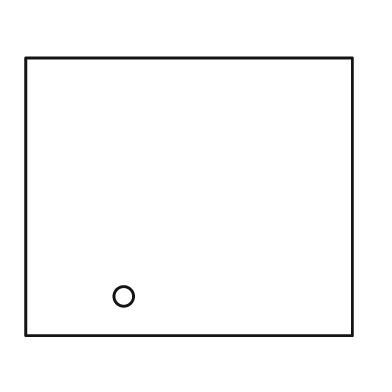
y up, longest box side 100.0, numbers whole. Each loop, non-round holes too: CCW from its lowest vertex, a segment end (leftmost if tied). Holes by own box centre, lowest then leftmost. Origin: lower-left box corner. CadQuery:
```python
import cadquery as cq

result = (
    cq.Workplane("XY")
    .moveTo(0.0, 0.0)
    .lineTo(100.0, 0.0)
    .lineTo(100.0, 85.0)
    .lineTo(0.0, 85.0)
    .close()
    .moveTo(30.0, 12.0)
    .circle(3.0)
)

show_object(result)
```